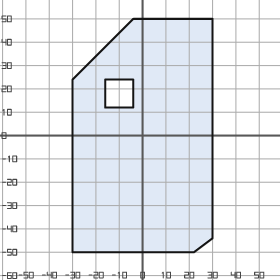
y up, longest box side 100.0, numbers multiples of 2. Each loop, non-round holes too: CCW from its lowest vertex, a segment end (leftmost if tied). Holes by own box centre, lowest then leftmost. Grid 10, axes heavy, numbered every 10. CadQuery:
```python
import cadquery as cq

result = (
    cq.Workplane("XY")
    .moveTo(-30.0, -50.0)
    .lineTo(22.0, -50.0)
    .lineTo(30.0, -44.0)
    .lineTo(30.0, 50.0)
    .lineTo(-4.0, 50.0)
    .lineTo(-30.0, 24.0)
    .close()
    .moveTo(-16.0, 12.0)
    .lineTo(-4.0, 12.0)
    .lineTo(-4.0, 24.0)
    .lineTo(-16.0, 24.0)
    .close()
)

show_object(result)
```